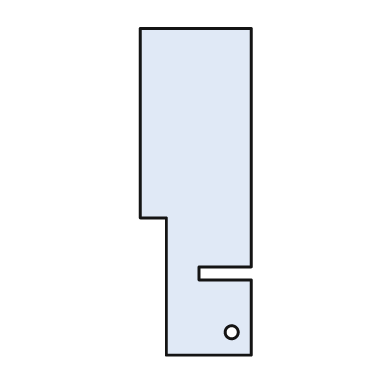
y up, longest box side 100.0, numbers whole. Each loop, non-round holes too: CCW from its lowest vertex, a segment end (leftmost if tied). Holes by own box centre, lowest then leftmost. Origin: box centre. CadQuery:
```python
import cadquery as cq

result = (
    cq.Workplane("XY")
    .moveTo(-9.0, -50.0)
    .lineTo(17.0, -50.0)
    .lineTo(17.0, -27.0)
    .lineTo(1.0, -27.0)
    .lineTo(1.0, -23.0)
    .lineTo(17.0, -23.0)
    .lineTo(17.0, 50.0)
    .lineTo(-17.0, 50.0)
    .lineTo(-17.0, -8.0)
    .lineTo(-9.0, -8.0)
    .close()
    .moveTo(11.0, -43.0)
    .circle(2.0)
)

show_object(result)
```